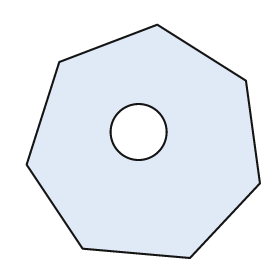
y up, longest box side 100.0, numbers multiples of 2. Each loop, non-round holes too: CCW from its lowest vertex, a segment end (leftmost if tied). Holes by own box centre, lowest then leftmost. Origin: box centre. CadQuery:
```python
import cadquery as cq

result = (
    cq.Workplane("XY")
    .moveTo(20.0, -50.0)
    .lineTo(50.0, -18.0)
    .lineTo(44.0, 26.0)
    .lineTo(6.0, 50.0)
    .lineTo(-36.0, 34.0)
    .lineTo(-50.0, -10.0)
    .lineTo(-26.0, -46.0)
    .close()
    .moveTo(-2.0, 4.0)
    .circle(12.0)
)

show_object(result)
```